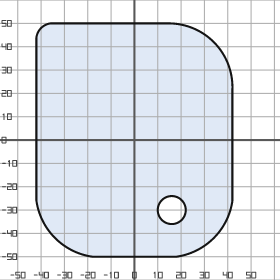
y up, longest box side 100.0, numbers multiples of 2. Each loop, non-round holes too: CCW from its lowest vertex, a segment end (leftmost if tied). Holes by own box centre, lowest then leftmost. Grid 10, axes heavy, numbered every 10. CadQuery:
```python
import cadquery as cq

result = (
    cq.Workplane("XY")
    .moveTo(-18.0, -50.0)
    .lineTo(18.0, -50.0)
    .threePointArc((34.0, -42.0), (42.0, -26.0))
    .lineTo(42.0, 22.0)
    .threePointArc((34.0, 42.0), (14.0, 50.0))
    .lineTo(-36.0, 50.0)
    .threePointArc((-40.0, 48.0), (-42.0, 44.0))
    .lineTo(-42.0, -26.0)
    .threePointArc((-34.0, -42.0), (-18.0, -50.0))
    .close()
    .moveTo(16.0, -30.0)
    .circle(6.0)
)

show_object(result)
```